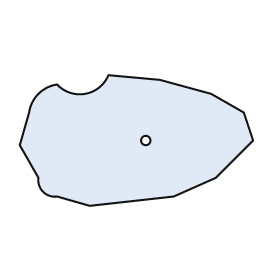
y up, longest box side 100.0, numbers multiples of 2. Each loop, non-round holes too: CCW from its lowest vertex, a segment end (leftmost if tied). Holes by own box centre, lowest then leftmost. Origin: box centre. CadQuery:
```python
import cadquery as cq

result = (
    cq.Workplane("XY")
    .moveTo(-20.0, -28.0)
    .lineTo(16.0, -24.0)
    .lineTo(34.0, -16.0)
    .lineTo(50.0, 0.0)
    .lineTo(46.0, 12.0)
    .lineTo(32.0, 20.0)
    .lineTo(10.0, 26.0)
    .lineTo(-12.0, 28.0)
    .threePointArc((-22.0, 20.0), (-34.0, 24.0))
    .threePointArc((-42.0, 20.0), (-46.0, 12.0))
    .lineTo(-50.0, -2.0)
    .lineTo(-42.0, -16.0)
    .threePointArc((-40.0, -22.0), (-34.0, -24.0))
    .close()
    .moveTo(4.0, 0.0)
    .circle(2.0)
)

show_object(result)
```